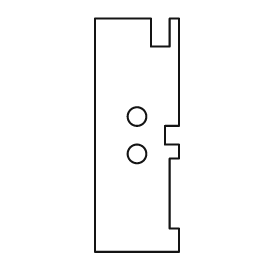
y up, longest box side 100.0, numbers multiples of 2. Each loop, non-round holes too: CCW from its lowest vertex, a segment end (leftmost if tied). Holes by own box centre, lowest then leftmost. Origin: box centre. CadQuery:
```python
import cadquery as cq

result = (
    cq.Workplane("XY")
    .moveTo(-18.0, -50.0)
    .lineTo(18.0, -50.0)
    .lineTo(18.0, -40.0)
    .lineTo(14.0, -40.0)
    .lineTo(14.0, -10.0)
    .lineTo(18.0, -10.0)
    .lineTo(18.0, -4.0)
    .lineTo(12.0, -4.0)
    .lineTo(12.0, 4.0)
    .lineTo(18.0, 4.0)
    .lineTo(18.0, 50.0)
    .lineTo(14.0, 50.0)
    .lineTo(14.0, 38.0)
    .lineTo(6.0, 38.0)
    .lineTo(6.0, 50.0)
    .lineTo(-18.0, 50.0)
    .close()
    .moveTo(0.0, -8.0)
    .circle(4.0)
    .moveTo(0.0, 8.0)
    .circle(4.0)
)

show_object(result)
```